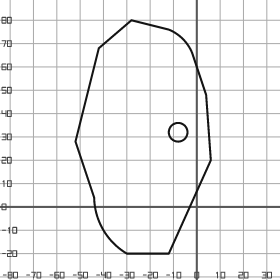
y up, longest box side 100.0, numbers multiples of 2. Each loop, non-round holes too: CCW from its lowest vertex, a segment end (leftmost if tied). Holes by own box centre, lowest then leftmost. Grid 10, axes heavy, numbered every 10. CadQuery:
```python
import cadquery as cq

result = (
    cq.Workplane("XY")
    .moveTo(-30.0, -20.0)
    .lineTo(-12.0, -20.0)
    .lineTo(6.0, 20.0)
    .lineTo(4.0, 48.0)
    .lineTo(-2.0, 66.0)
    .threePointArc((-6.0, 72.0), (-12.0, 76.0))
    .lineTo(-28.0, 80.0)
    .lineTo(-42.0, 68.0)
    .lineTo(-52.0, 28.0)
    .lineTo(-44.0, 4.0)
    .threePointArc((-40.0, -10.0), (-30.0, -20.0))
    .close()
    .moveTo(-8.0, 32.0)
    .circle(4.0)
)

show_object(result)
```